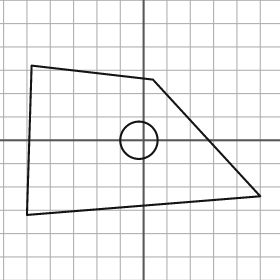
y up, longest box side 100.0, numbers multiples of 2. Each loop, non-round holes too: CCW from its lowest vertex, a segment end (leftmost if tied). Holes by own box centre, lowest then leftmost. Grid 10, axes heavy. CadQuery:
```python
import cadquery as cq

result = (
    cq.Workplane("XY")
    .moveTo(-50.0, -32.0)
    .lineTo(50.0, -24.0)
    .lineTo(4.0, 26.0)
    .lineTo(-48.0, 32.0)
    .close()
    .moveTo(-2.0, 0.0)
    .circle(8.0)
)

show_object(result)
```